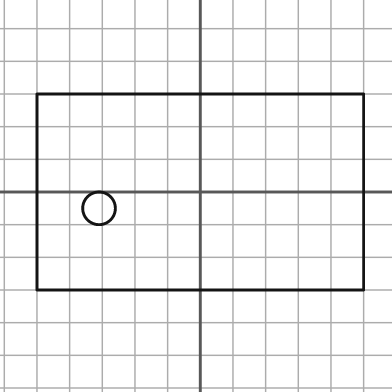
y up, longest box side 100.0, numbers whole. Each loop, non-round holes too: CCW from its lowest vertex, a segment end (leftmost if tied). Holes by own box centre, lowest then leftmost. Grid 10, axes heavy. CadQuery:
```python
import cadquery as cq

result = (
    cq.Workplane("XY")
    .moveTo(-50.0, -30.0)
    .lineTo(50.0, -30.0)
    .lineTo(50.0, 30.0)
    .lineTo(-50.0, 30.0)
    .close()
    .moveTo(-31.0, -5.0)
    .circle(5.0)
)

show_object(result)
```